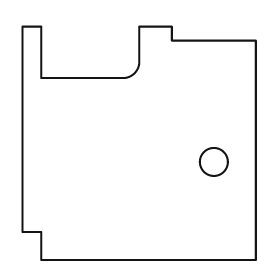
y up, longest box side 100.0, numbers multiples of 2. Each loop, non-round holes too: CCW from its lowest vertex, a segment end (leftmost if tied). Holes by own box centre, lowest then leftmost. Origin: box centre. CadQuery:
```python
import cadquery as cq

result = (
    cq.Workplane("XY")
    .moveTo(-42.0, -50.0)
    .lineTo(50.0, -50.0)
    .lineTo(50.0, 44.0)
    .lineTo(14.0, 44.0)
    .lineTo(14.0, 50.0)
    .lineTo(0.0, 50.0)
    .lineTo(0.0, 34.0)
    .threePointArc((-2.0, 30.0), (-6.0, 28.0))
    .lineTo(-42.0, 28.0)
    .lineTo(-42.0, 50.0)
    .lineTo(-50.0, 50.0)
    .lineTo(-50.0, -38.0)
    .lineTo(-42.0, -38.0)
    .close()
    .moveTo(32.0, -8.0)
    .circle(6.0)
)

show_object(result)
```